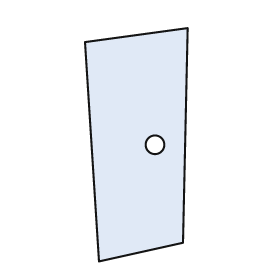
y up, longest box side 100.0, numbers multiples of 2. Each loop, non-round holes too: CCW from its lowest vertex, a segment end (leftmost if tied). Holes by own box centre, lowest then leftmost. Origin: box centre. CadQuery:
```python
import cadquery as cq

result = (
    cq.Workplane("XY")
    .moveTo(-16.0, -50.0)
    .lineTo(20.0, -42.0)
    .lineTo(22.0, 50.0)
    .lineTo(-22.0, 44.0)
    .close()
    .moveTo(8.0, 0.0)
    .circle(4.0)
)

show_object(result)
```